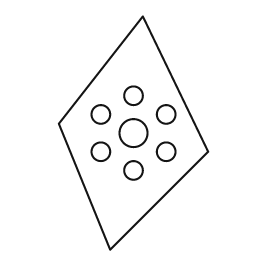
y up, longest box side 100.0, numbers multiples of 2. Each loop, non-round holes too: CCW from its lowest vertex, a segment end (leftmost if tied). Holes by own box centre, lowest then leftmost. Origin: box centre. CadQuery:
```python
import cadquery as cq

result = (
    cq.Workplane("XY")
    .moveTo(-10.0, -50.0)
    .lineTo(32.0, -8.0)
    .lineTo(4.0, 50.0)
    .lineTo(-32.0, 4.0)
    .close()
    .moveTo(0.0, -16.0)
    .circle(4.0)
    .moveTo(-14.0, -8.0)
    .circle(4.0)
    .moveTo(14.0, -8.0)
    .circle(4.0)
    .moveTo(0.0, 0.0)
    .circle(6.0)
    .moveTo(-14.0, 8.0)
    .circle(4.0)
    .moveTo(14.0, 8.0)
    .circle(4.0)
    .moveTo(0.0, 16.0)
    .circle(4.0)
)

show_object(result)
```